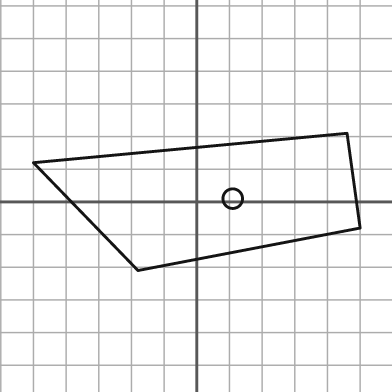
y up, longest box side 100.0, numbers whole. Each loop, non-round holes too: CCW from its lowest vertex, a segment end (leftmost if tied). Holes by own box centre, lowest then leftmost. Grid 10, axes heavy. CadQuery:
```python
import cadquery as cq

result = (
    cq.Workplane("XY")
    .moveTo(-18.0, -21.0)
    .lineTo(50.0, -8.0)
    .lineTo(46.0, 21.0)
    .lineTo(-50.0, 12.0)
    .close()
    .moveTo(11.0, 1.0)
    .circle(3.0)
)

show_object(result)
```